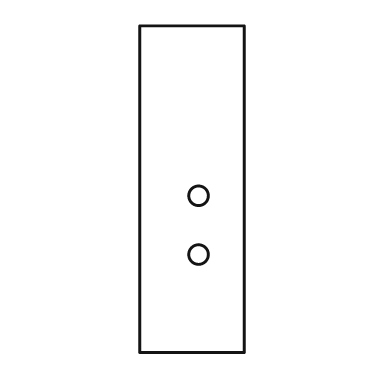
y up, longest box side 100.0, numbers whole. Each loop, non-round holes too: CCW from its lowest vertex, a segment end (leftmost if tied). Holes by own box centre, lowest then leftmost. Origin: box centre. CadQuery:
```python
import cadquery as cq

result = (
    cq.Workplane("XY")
    .moveTo(-16.0, -50.0)
    .lineTo(16.0, -50.0)
    .lineTo(16.0, 50.0)
    .lineTo(-16.0, 50.0)
    .close()
    .moveTo(2.0, -20.0)
    .circle(3.0)
    .moveTo(2.0, -2.0)
    .circle(3.0)
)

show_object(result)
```